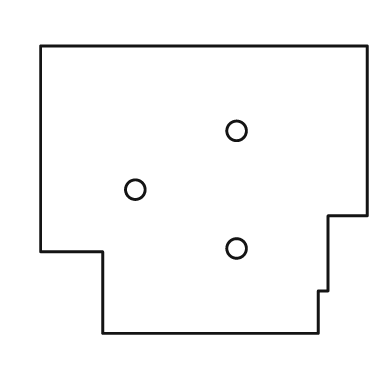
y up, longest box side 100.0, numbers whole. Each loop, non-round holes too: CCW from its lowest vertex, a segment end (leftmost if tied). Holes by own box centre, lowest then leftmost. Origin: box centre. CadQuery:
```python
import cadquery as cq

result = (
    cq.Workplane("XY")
    .moveTo(-31.0, -44.0)
    .lineTo(35.0, -44.0)
    .lineTo(35.0, -31.0)
    .lineTo(38.0, -31.0)
    .lineTo(38.0, -8.0)
    .lineTo(50.0, -8.0)
    .lineTo(50.0, 44.0)
    .lineTo(-50.0, 44.0)
    .lineTo(-50.0, -19.0)
    .lineTo(-31.0, -19.0)
    .close()
    .moveTo(10.0, -18.0)
    .circle(3.0)
    .moveTo(-21.0, 0.0)
    .circle(3.0)
    .moveTo(10.0, 18.0)
    .circle(3.0)
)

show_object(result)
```